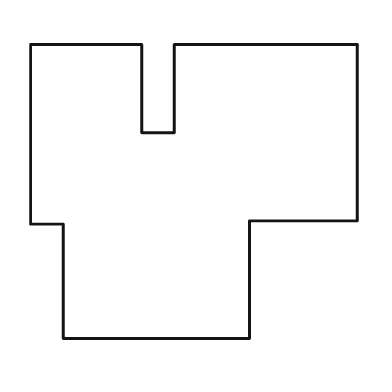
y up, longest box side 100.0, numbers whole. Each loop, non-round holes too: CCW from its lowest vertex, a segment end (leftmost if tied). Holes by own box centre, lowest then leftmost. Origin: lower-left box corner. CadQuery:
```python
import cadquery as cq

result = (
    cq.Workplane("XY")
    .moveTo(10.0, 0.0)
    .lineTo(67.0, 0.0)
    .lineTo(67.0, 36.0)
    .lineTo(100.0, 36.0)
    .lineTo(100.0, 90.0)
    .lineTo(44.0, 90.0)
    .lineTo(44.0, 63.0)
    .lineTo(34.0, 63.0)
    .lineTo(34.0, 90.0)
    .lineTo(0.0, 90.0)
    .lineTo(0.0, 35.0)
    .lineTo(10.0, 35.0)
    .close()
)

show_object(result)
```